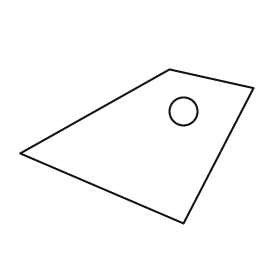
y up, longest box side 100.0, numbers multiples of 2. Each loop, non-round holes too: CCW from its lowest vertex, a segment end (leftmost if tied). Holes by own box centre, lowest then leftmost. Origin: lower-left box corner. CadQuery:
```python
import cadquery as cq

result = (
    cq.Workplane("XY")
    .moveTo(70.0, 0.0)
    .lineTo(100.0, 58.0)
    .lineTo(64.0, 66.0)
    .lineTo(0.0, 30.0)
    .close()
    .moveTo(70.0, 48.0)
    .circle(6.0)
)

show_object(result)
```